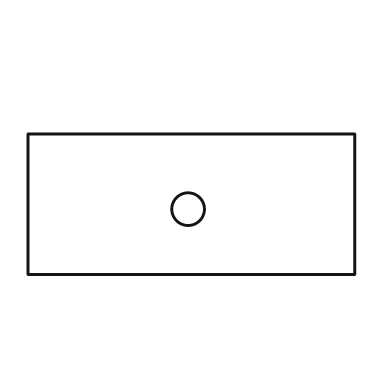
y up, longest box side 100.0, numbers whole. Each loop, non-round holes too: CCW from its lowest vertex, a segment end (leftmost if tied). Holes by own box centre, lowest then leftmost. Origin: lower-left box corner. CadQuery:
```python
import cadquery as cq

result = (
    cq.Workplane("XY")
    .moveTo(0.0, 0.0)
    .lineTo(100.0, 0.0)
    .lineTo(100.0, 43.0)
    .lineTo(0.0, 43.0)
    .close()
    .moveTo(49.0, 20.0)
    .circle(5.0)
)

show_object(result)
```